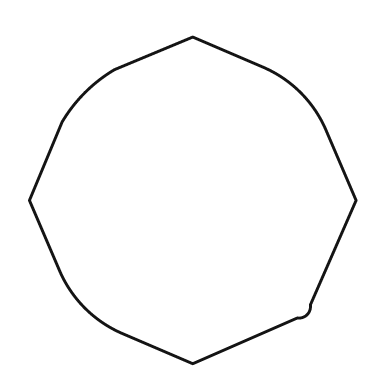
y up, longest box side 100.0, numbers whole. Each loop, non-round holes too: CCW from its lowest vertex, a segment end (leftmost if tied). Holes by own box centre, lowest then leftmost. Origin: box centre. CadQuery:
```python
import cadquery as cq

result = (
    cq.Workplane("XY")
    .moveTo(0.0, -50.0)
    .lineTo(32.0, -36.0)
    .threePointArc((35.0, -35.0), (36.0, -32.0))
    .lineTo(50.0, 0.0)
    .lineTo(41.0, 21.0)
    .threePointArc((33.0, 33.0), (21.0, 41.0))
    .lineTo(0.0, 50.0)
    .lineTo(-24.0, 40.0)
    .threePointArc((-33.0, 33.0), (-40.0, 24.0))
    .lineTo(-50.0, 0.0)
    .lineTo(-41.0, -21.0)
    .threePointArc((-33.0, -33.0), (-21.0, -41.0))
    .close()
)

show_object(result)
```